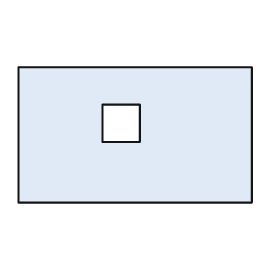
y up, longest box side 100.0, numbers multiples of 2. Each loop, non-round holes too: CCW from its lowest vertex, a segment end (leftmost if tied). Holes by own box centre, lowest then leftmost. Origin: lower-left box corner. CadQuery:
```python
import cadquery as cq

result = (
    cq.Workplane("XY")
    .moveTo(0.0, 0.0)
    .lineTo(100.0, 0.0)
    .lineTo(100.0, 58.0)
    .lineTo(0.0, 58.0)
    .close()
    .moveTo(36.0, 26.0)
    .lineTo(52.0, 26.0)
    .lineTo(52.0, 42.0)
    .lineTo(36.0, 42.0)
    .close()
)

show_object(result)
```